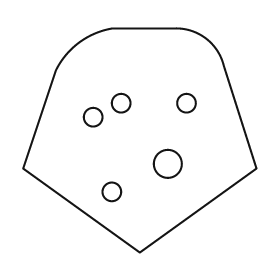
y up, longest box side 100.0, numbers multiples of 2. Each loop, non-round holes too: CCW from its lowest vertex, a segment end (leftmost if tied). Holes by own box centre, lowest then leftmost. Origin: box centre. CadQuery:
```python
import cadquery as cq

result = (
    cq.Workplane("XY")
    .moveTo(0.0, -48.0)
    .lineTo(50.0, -12.0)
    .lineTo(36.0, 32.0)
    .threePointArc((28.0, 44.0), (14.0, 48.0))
    .lineTo(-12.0, 48.0)
    .threePointArc((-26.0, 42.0), (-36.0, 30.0))
    .lineTo(-50.0, -12.0)
    .close()
    .moveTo(-12.0, -22.0)
    .circle(4.0)
    .moveTo(12.0, -10.0)
    .circle(6.0)
    .moveTo(-20.0, 10.0)
    .circle(4.0)
    .moveTo(-8.0, 16.0)
    .circle(4.0)
    .moveTo(20.0, 16.0)
    .circle(4.0)
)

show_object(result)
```